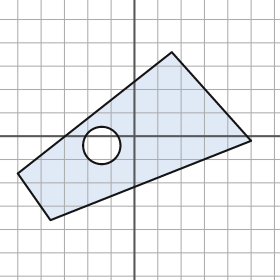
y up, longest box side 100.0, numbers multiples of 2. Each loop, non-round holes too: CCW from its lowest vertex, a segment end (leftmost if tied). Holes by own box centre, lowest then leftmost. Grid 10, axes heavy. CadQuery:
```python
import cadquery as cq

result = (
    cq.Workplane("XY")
    .moveTo(-36.0, -36.0)
    .lineTo(50.0, -2.0)
    .lineTo(16.0, 36.0)
    .lineTo(-50.0, -16.0)
    .close()
    .moveTo(-14.0, -4.0)
    .circle(8.0)
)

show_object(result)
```